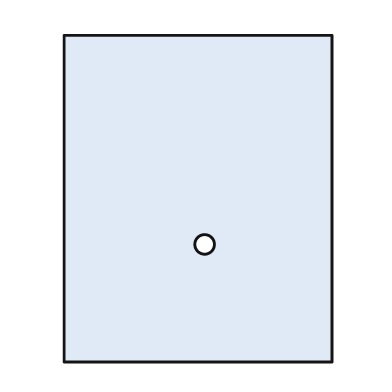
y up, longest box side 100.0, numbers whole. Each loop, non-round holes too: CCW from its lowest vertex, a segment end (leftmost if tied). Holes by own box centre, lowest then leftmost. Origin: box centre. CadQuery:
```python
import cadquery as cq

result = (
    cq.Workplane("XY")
    .moveTo(-41.0, -50.0)
    .lineTo(41.0, -50.0)
    .lineTo(41.0, 50.0)
    .lineTo(-41.0, 50.0)
    .close()
    .moveTo(2.0, -14.0)
    .circle(3.0)
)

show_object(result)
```